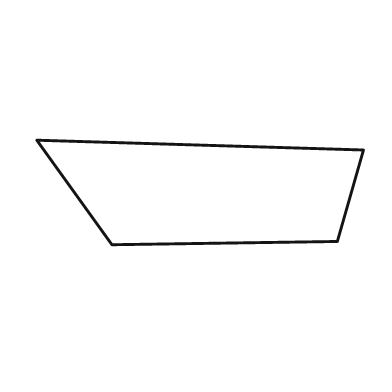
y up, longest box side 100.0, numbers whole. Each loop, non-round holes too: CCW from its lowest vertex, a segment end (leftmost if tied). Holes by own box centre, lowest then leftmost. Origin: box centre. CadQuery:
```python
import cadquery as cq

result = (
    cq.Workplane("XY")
    .moveTo(-27.0, -16.0)
    .lineTo(42.0, -15.0)
    .lineTo(50.0, 13.0)
    .lineTo(-50.0, 16.0)
    .close()
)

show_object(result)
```